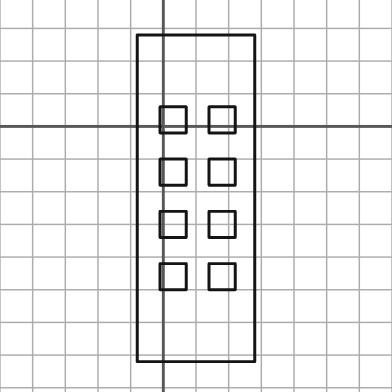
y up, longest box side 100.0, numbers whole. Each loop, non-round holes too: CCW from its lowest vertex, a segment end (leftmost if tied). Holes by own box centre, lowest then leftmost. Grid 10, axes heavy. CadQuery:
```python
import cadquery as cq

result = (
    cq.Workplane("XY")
    .moveTo(-8.0, -72.0)
    .lineTo(28.0, -72.0)
    .lineTo(28.0, 28.0)
    .lineTo(-8.0, 28.0)
    .close()
    .moveTo(-1.0, -50.0)
    .lineTo(7.0, -50.0)
    .lineTo(7.0, -42.0)
    .lineTo(-1.0, -42.0)
    .close()
    .moveTo(14.0, -50.0)
    .lineTo(22.0, -50.0)
    .lineTo(22.0, -42.0)
    .lineTo(14.0, -42.0)
    .close()
    .moveTo(-1.0, -34.0)
    .lineTo(7.0, -34.0)
    .lineTo(7.0, -26.0)
    .lineTo(-1.0, -26.0)
    .close()
    .moveTo(14.0, -34.0)
    .lineTo(22.0, -34.0)
    .lineTo(22.0, -26.0)
    .lineTo(14.0, -26.0)
    .close()
    .moveTo(-1.0, -18.0)
    .lineTo(7.0, -18.0)
    .lineTo(7.0, -10.0)
    .lineTo(-1.0, -10.0)
    .close()
    .moveTo(14.0, -18.0)
    .lineTo(22.0, -18.0)
    .lineTo(22.0, -10.0)
    .lineTo(14.0, -10.0)
    .close()
    .moveTo(-1.0, -2.0)
    .lineTo(7.0, -2.0)
    .lineTo(7.0, 6.0)
    .lineTo(-1.0, 6.0)
    .close()
    .moveTo(14.0, -2.0)
    .lineTo(22.0, -2.0)
    .lineTo(22.0, 6.0)
    .lineTo(14.0, 6.0)
    .close()
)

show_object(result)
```